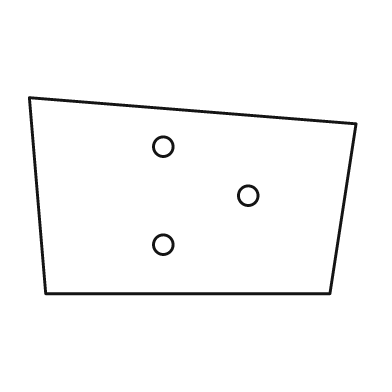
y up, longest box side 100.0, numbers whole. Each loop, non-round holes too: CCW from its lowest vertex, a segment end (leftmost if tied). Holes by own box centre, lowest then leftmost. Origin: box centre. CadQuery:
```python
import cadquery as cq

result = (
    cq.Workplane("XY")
    .moveTo(-45.0, -30.0)
    .lineTo(42.0, -30.0)
    .lineTo(50.0, 22.0)
    .lineTo(-50.0, 30.0)
    .close()
    .moveTo(-9.0, -15.0)
    .circle(3.0)
    .moveTo(17.0, 0.0)
    .circle(3.0)
    .moveTo(-9.0, 15.0)
    .circle(3.0)
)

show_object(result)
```